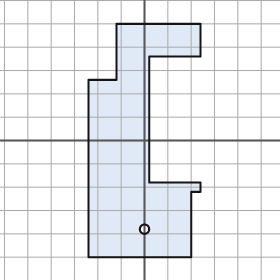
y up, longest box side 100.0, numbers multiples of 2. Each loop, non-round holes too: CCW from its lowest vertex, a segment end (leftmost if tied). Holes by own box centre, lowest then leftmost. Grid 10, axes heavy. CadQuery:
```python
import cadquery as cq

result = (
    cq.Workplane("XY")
    .moveTo(-24.0, -50.0)
    .lineTo(20.0, -50.0)
    .lineTo(20.0, -22.0)
    .lineTo(24.0, -22.0)
    .lineTo(24.0, -18.0)
    .lineTo(2.0, -18.0)
    .lineTo(2.0, 36.0)
    .lineTo(24.0, 36.0)
    .lineTo(24.0, 50.0)
    .lineTo(-12.0, 50.0)
    .lineTo(-12.0, 26.0)
    .lineTo(-24.0, 26.0)
    .close()
    .moveTo(0.0, -38.0)
    .circle(2.0)
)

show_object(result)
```